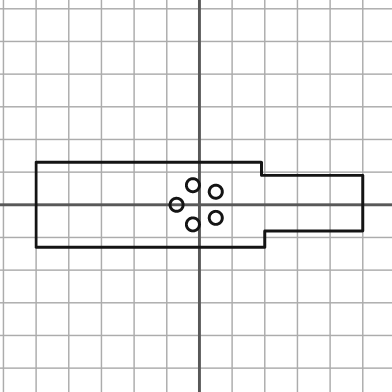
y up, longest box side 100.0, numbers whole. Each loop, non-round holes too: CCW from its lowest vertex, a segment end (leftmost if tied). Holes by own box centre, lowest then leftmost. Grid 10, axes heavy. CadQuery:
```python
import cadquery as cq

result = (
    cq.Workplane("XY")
    .moveTo(-50.0, -13.0)
    .lineTo(20.0, -13.0)
    .lineTo(20.0, -8.0)
    .lineTo(50.0, -8.0)
    .lineTo(50.0, 9.0)
    .lineTo(19.0, 9.0)
    .lineTo(19.0, 13.0)
    .lineTo(-50.0, 13.0)
    .close()
    .moveTo(-2.0, -6.0)
    .circle(2.0)
    .moveTo(5.0, -4.0)
    .circle(2.0)
    .moveTo(-7.0, 0.0)
    .circle(2.0)
    .moveTo(5.0, 4.0)
    .circle(2.0)
    .moveTo(-2.0, 6.0)
    .circle(2.0)
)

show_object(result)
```